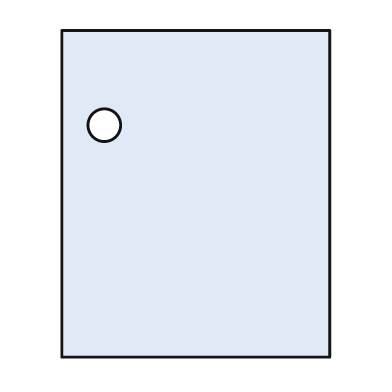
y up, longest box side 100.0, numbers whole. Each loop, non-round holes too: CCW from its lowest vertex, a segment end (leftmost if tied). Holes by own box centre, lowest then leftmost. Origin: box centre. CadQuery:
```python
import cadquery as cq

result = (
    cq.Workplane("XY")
    .moveTo(-41.0, -50.0)
    .lineTo(41.0, -50.0)
    .lineTo(41.0, 50.0)
    .lineTo(-41.0, 50.0)
    .close()
    .moveTo(-28.0, 21.0)
    .circle(5.0)
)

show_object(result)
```